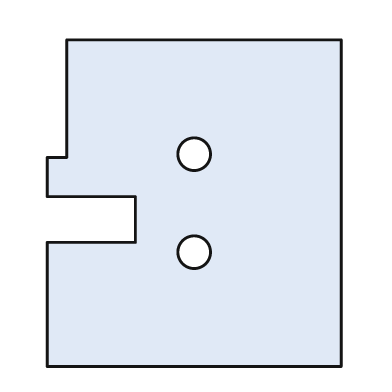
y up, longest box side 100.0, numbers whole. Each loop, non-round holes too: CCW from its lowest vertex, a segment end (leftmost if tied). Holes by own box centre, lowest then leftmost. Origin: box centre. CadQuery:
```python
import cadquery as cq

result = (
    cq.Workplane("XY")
    .moveTo(-45.0, -50.0)
    .lineTo(45.0, -50.0)
    .lineTo(45.0, 50.0)
    .lineTo(-39.0, 50.0)
    .lineTo(-39.0, 14.0)
    .lineTo(-45.0, 14.0)
    .lineTo(-45.0, 2.0)
    .lineTo(-18.0, 2.0)
    .lineTo(-18.0, -12.0)
    .lineTo(-45.0, -12.0)
    .close()
    .moveTo(0.0, -15.0)
    .circle(5.0)
    .moveTo(0.0, 15.0)
    .circle(5.0)
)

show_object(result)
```